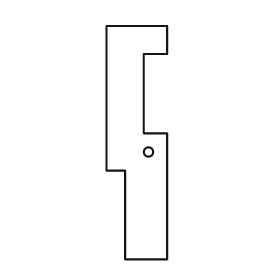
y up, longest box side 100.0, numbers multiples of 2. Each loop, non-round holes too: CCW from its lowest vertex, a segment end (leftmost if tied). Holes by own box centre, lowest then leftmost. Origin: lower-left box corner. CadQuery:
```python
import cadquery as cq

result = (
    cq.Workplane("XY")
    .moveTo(8.0, 0.0)
    .lineTo(26.0, 0.0)
    .lineTo(26.0, 54.0)
    .lineTo(16.0, 54.0)
    .lineTo(16.0, 88.0)
    .lineTo(26.0, 88.0)
    .lineTo(26.0, 100.0)
    .lineTo(0.0, 100.0)
    .lineTo(0.0, 38.0)
    .lineTo(8.0, 38.0)
    .close()
    .moveTo(18.0, 46.0)
    .circle(2.0)
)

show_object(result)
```